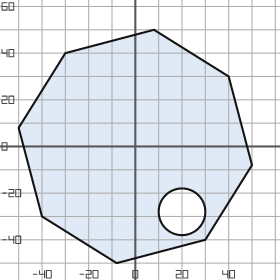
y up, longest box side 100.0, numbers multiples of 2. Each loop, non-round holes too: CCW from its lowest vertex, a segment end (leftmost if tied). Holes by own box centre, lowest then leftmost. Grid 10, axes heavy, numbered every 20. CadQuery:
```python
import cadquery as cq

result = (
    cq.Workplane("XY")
    .moveTo(-8.0, -50.0)
    .lineTo(30.0, -40.0)
    .lineTo(50.0, -8.0)
    .lineTo(40.0, 30.0)
    .lineTo(8.0, 50.0)
    .lineTo(-30.0, 40.0)
    .lineTo(-50.0, 8.0)
    .lineTo(-40.0, -30.0)
    .close()
    .moveTo(20.0, -28.0)
    .circle(10.0)
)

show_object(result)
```